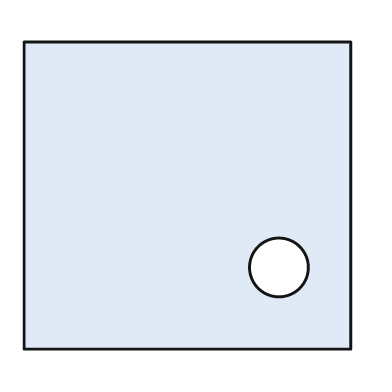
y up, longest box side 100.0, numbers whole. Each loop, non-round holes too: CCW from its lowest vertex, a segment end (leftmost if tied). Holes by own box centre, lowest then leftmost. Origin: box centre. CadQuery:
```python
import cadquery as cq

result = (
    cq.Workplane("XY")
    .moveTo(-50.0, -47.0)
    .lineTo(50.0, -47.0)
    .lineTo(50.0, 47.0)
    .lineTo(-50.0, 47.0)
    .close()
    .moveTo(28.0, -22.0)
    .circle(9.0)
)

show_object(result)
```